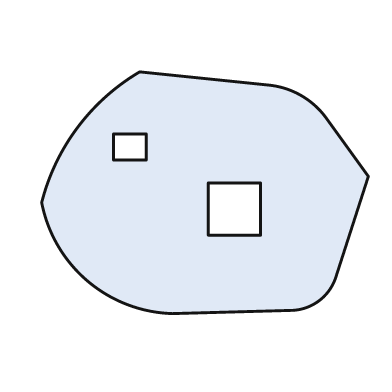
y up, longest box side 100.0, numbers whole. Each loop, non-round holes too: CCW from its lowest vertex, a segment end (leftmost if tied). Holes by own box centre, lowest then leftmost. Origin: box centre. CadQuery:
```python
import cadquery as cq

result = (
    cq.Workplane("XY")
    .moveTo(-10.0, -37.0)
    .lineTo(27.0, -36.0)
    .threePointArc((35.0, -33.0), (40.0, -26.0))
    .lineTo(50.0, 5.0)
    .lineTo(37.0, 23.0)
    .threePointArc((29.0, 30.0), (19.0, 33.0))
    .lineTo(-20.0, 37.0)
    .threePointArc((-39.0, 20.0), (-50.0, -3.0))
    .threePointArc((-36.0, -27.0), (-10.0, -37.0))
    .close()
    .moveTo(1.0, -13.0)
    .lineTo(17.0, -13.0)
    .lineTo(17.0, 3.0)
    .lineTo(1.0, 3.0)
    .close()
    .moveTo(-28.0, 10.0)
    .lineTo(-18.0, 10.0)
    .lineTo(-18.0, 18.0)
    .lineTo(-28.0, 18.0)
    .close()
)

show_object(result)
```